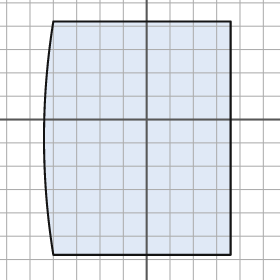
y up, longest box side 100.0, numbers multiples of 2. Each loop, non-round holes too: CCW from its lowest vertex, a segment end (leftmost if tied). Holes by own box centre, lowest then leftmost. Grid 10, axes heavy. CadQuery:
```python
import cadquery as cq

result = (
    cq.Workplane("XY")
    .moveTo(-40.0, -58.0)
    .lineTo(36.0, -58.0)
    .lineTo(36.0, 42.0)
    .lineTo(-40.0, 42.0)
    .threePointArc((-44.0, -8.0), (-40.0, -58.0))
    .close()
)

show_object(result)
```